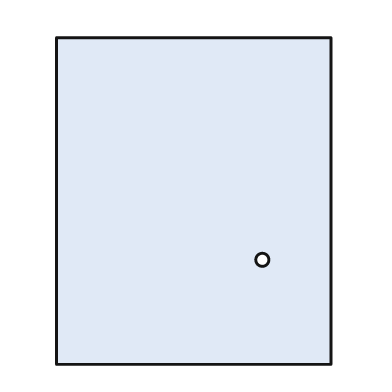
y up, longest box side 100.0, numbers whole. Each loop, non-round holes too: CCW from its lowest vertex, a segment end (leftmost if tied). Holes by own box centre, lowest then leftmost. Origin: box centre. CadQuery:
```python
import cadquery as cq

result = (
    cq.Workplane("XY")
    .moveTo(-42.0, -50.0)
    .lineTo(42.0, -50.0)
    .lineTo(42.0, 50.0)
    .lineTo(-42.0, 50.0)
    .close()
    .moveTo(21.0, -18.0)
    .circle(2.0)
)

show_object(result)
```